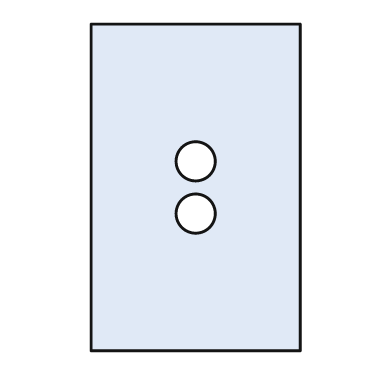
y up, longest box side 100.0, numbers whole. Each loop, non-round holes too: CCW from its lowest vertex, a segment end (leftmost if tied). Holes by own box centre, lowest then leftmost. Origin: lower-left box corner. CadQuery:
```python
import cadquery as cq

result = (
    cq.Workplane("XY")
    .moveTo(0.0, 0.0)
    .lineTo(64.0, 0.0)
    .lineTo(64.0, 100.0)
    .lineTo(0.0, 100.0)
    .close()
    .moveTo(32.0, 42.0)
    .circle(6.0)
    .moveTo(32.0, 58.0)
    .circle(6.0)
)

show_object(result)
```